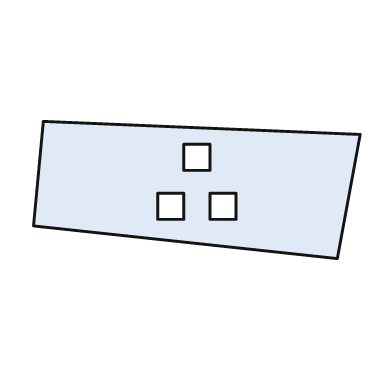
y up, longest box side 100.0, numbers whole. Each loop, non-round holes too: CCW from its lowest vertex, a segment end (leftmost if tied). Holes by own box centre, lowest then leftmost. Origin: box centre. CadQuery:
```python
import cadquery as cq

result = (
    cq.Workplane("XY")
    .moveTo(43.0, -21.0)
    .lineTo(50.0, 17.0)
    .lineTo(-47.0, 21.0)
    .lineTo(-50.0, -11.0)
    .close()
    .moveTo(-12.0, -9.0)
    .lineTo(-4.0, -9.0)
    .lineTo(-4.0, -1.0)
    .lineTo(-12.0, -1.0)
    .close()
    .moveTo(4.0, -9.0)
    .lineTo(12.0, -9.0)
    .lineTo(12.0, -1.0)
    .lineTo(4.0, -1.0)
    .close()
    .moveTo(-4.0, 6.0)
    .lineTo(4.0, 6.0)
    .lineTo(4.0, 14.0)
    .lineTo(-4.0, 14.0)
    .close()
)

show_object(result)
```